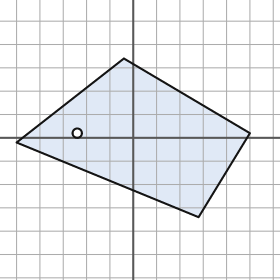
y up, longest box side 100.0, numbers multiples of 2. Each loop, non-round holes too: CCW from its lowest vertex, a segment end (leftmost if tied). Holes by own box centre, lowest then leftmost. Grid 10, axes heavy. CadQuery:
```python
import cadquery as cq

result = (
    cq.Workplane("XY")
    .moveTo(28.0, -34.0)
    .lineTo(50.0, 2.0)
    .lineTo(-4.0, 34.0)
    .lineTo(-50.0, -2.0)
    .close()
    .moveTo(-24.0, 2.0)
    .circle(2.0)
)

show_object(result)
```